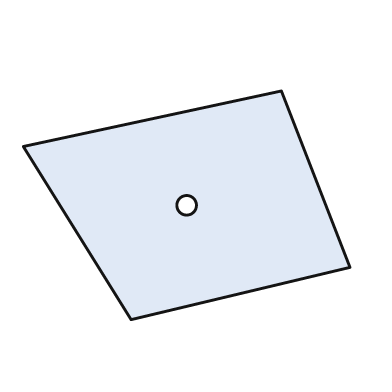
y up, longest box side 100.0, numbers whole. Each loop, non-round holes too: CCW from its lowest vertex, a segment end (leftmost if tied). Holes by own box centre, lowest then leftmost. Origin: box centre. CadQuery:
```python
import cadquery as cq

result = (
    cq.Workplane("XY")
    .moveTo(-17.0, -35.0)
    .lineTo(50.0, -19.0)
    .lineTo(29.0, 35.0)
    .lineTo(-50.0, 18.0)
    .close()
    .moveTo(0.0, 0.0)
    .circle(3.0)
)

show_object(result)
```